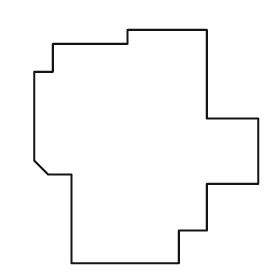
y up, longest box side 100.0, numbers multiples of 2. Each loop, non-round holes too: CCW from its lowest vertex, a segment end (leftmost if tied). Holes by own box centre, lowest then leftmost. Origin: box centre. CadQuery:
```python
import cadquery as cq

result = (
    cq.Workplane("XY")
    .moveTo(-32.0, -50.0)
    .lineTo(14.0, -50.0)
    .lineTo(14.0, -36.0)
    .lineTo(26.0, -36.0)
    .lineTo(26.0, -16.0)
    .lineTo(48.0, -16.0)
    .lineTo(48.0, 12.0)
    .lineTo(26.0, 12.0)
    .lineTo(26.0, 50.0)
    .lineTo(-8.0, 50.0)
    .lineTo(-8.0, 44.0)
    .lineTo(-40.0, 44.0)
    .lineTo(-40.0, 32.0)
    .lineTo(-48.0, 32.0)
    .lineTo(-48.0, -6.0)
    .lineTo(-42.0, -12.0)
    .lineTo(-32.0, -12.0)
    .close()
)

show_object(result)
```